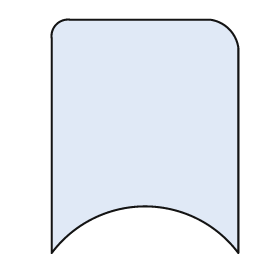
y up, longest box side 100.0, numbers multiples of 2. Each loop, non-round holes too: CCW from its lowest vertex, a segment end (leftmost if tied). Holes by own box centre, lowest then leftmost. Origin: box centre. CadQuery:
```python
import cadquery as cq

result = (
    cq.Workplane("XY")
    .moveTo(-40.0, -50.0)
    .threePointArc((0.0, -30.0), (40.0, -50.0))
    .lineTo(40.0, 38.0)
    .threePointArc((36.0, 46.0), (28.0, 50.0))
    .lineTo(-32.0, 50.0)
    .threePointArc((-38.0, 48.0), (-40.0, 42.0))
    .close()
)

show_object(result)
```